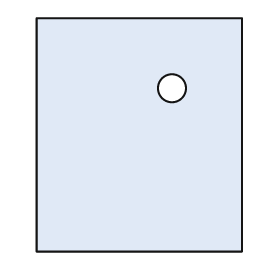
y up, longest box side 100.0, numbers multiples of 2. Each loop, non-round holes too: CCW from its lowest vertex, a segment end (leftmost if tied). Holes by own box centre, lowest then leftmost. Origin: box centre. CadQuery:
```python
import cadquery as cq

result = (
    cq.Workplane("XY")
    .moveTo(-44.0, -50.0)
    .lineTo(44.0, -50.0)
    .lineTo(44.0, 50.0)
    .lineTo(-44.0, 50.0)
    .close()
    .moveTo(14.0, 20.0)
    .circle(6.0)
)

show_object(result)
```